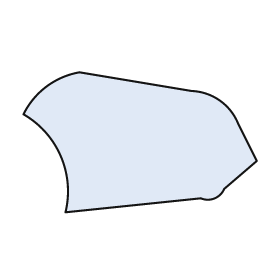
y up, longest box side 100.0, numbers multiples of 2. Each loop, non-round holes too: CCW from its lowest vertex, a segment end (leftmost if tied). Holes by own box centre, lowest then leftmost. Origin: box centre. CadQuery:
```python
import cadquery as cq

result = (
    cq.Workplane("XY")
    .moveTo(-32.0, -30.0)
    .lineTo(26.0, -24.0)
    .threePointArc((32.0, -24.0), (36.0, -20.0))
    .lineTo(50.0, -8.0)
    .lineTo(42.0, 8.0)
    .threePointArc((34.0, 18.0), (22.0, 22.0))
    .lineTo(-26.0, 30.0)
    .threePointArc((-40.0, 24.0), (-50.0, 12.0))
    .threePointArc((-34.0, -6.0), (-32.0, -30.0))
    .close()
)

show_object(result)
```